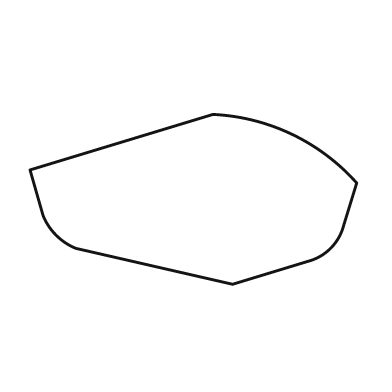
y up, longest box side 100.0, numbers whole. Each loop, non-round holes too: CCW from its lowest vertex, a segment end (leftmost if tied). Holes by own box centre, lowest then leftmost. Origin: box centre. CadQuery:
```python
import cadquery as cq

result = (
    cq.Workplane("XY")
    .moveTo(12.0, -26.0)
    .lineTo(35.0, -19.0)
    .threePointArc((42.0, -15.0), (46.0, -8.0))
    .lineTo(50.0, 5.0)
    .threePointArc((30.0, 20.0), (6.0, 26.0))
    .lineTo(-50.0, 9.0)
    .lineTo(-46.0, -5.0)
    .threePointArc((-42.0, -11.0), (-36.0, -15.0))
    .close()
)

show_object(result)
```